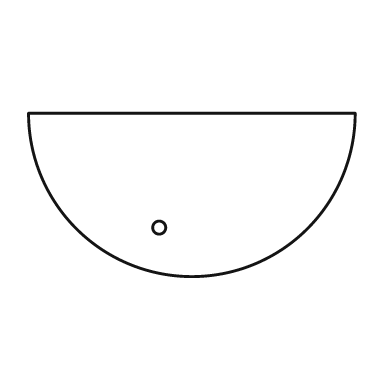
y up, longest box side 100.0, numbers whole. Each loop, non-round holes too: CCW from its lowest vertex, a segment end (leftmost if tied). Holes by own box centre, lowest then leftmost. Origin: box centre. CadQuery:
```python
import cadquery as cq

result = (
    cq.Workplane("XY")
    .moveTo(-50.0, 25.0)
    .threePointArc((0.0, -25.0), (50.0, 25.0))
    .close()
    .moveTo(-10.0, -10.0)
    .circle(2.0)
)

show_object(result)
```